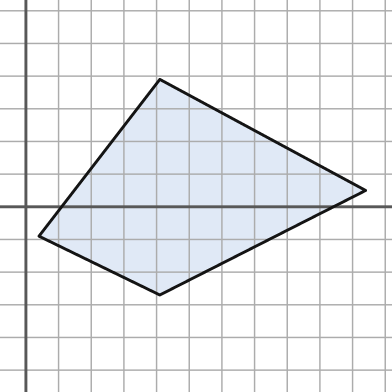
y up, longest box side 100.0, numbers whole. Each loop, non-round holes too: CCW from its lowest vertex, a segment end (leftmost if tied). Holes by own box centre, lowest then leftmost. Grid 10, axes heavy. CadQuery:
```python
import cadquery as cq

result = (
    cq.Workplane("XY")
    .moveTo(41.0, -27.0)
    .lineTo(104.0, 5.0)
    .lineTo(41.0, 39.0)
    .lineTo(4.0, -9.0)
    .close()
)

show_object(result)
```